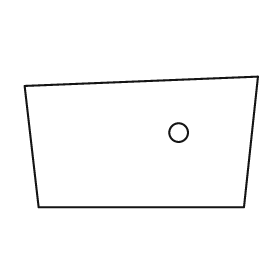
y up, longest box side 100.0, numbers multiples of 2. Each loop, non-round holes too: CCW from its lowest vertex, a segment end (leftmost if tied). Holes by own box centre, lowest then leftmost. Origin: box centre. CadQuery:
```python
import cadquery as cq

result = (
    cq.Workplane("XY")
    .moveTo(-44.0, -28.0)
    .lineTo(44.0, -28.0)
    .lineTo(50.0, 28.0)
    .lineTo(-50.0, 24.0)
    .close()
    .moveTo(16.0, 4.0)
    .circle(4.0)
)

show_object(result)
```